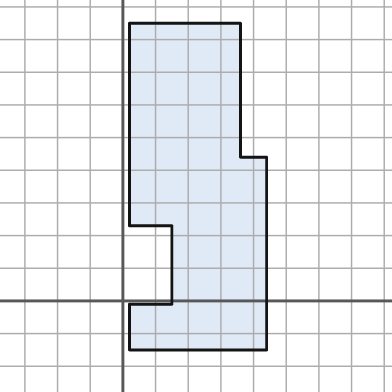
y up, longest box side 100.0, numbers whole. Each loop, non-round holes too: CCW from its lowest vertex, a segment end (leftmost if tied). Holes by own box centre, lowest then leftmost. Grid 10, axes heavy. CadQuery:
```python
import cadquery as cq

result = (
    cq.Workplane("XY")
    .moveTo(2.0, -15.0)
    .lineTo(44.0, -15.0)
    .lineTo(44.0, 44.0)
    .lineTo(36.0, 44.0)
    .lineTo(36.0, 85.0)
    .lineTo(2.0, 85.0)
    .lineTo(2.0, 23.0)
    .lineTo(15.0, 23.0)
    .lineTo(15.0, -1.0)
    .lineTo(2.0, -1.0)
    .close()
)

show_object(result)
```